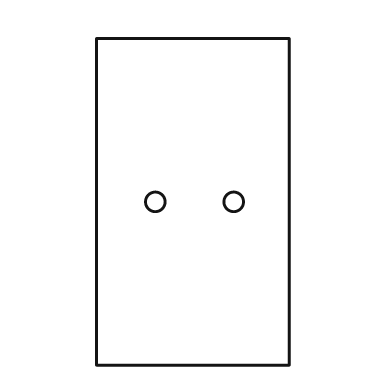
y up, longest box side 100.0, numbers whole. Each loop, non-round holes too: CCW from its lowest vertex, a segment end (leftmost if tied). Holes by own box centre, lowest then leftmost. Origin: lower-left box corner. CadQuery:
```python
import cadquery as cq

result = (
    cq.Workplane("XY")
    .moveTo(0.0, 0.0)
    .lineTo(59.0, 0.0)
    .lineTo(59.0, 100.0)
    .lineTo(0.0, 100.0)
    .close()
    .moveTo(18.0, 50.0)
    .circle(3.0)
    .moveTo(42.0, 50.0)
    .circle(3.0)
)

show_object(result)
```